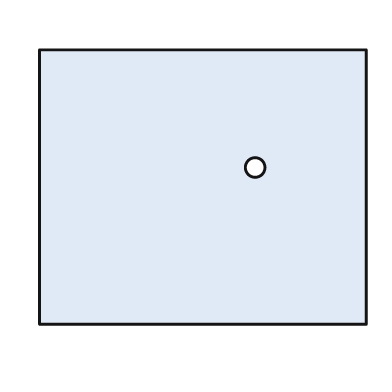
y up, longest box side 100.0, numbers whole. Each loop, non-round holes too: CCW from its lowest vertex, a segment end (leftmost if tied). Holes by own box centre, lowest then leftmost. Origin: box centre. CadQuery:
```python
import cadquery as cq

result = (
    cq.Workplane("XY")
    .moveTo(-50.0, -42.0)
    .lineTo(50.0, -42.0)
    .lineTo(50.0, 42.0)
    .lineTo(-50.0, 42.0)
    .close()
    .moveTo(16.0, 6.0)
    .circle(3.0)
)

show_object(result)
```